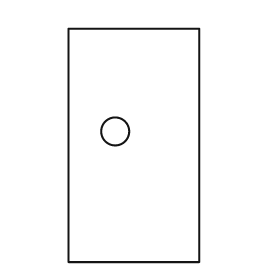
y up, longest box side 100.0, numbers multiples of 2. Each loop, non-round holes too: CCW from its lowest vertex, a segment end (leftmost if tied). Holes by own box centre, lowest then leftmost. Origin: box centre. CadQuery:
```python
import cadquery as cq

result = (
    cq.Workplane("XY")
    .moveTo(-28.0, -50.0)
    .lineTo(28.0, -50.0)
    .lineTo(28.0, 50.0)
    .lineTo(-28.0, 50.0)
    .close()
    .moveTo(-8.0, 6.0)
    .circle(6.0)
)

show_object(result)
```